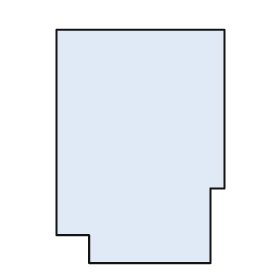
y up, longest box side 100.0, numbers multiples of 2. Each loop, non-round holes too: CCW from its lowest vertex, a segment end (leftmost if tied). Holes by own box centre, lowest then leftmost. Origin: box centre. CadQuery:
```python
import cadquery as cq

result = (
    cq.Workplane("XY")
    .moveTo(-22.0, -50.0)
    .lineTo(30.0, -50.0)
    .lineTo(30.0, -18.0)
    .lineTo(36.0, -18.0)
    .lineTo(36.0, 50.0)
    .lineTo(-36.0, 50.0)
    .lineTo(-36.0, -38.0)
    .lineTo(-22.0, -38.0)
    .close()
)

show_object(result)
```